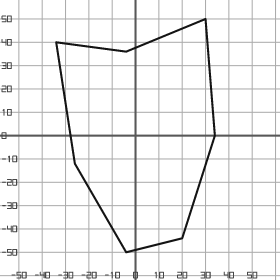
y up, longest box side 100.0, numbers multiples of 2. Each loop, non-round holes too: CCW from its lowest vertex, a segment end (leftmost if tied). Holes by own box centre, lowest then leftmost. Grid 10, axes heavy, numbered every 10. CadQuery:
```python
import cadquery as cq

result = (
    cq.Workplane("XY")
    .moveTo(-4.0, -50.0)
    .lineTo(20.0, -44.0)
    .lineTo(34.0, 0.0)
    .lineTo(30.0, 50.0)
    .lineTo(-4.0, 36.0)
    .lineTo(-34.0, 40.0)
    .lineTo(-26.0, -12.0)
    .close()
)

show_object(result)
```